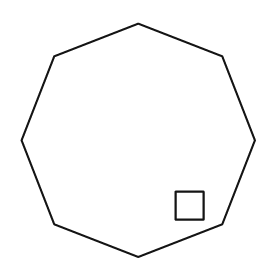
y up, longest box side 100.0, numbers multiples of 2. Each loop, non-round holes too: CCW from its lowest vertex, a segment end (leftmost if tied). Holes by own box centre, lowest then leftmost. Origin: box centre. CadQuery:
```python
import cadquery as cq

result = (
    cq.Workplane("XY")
    .moveTo(0.0, -50.0)
    .lineTo(36.0, -36.0)
    .lineTo(50.0, 0.0)
    .lineTo(36.0, 36.0)
    .lineTo(0.0, 50.0)
    .lineTo(-36.0, 36.0)
    .lineTo(-50.0, 0.0)
    .lineTo(-36.0, -36.0)
    .close()
    .moveTo(16.0, -34.0)
    .lineTo(28.0, -34.0)
    .lineTo(28.0, -22.0)
    .lineTo(16.0, -22.0)
    .close()
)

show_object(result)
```